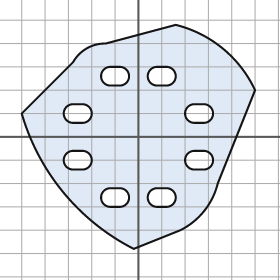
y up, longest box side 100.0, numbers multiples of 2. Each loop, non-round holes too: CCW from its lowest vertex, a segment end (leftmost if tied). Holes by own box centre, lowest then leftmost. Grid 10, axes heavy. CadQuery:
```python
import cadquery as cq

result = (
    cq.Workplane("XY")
    .moveTo(-2.0, -48.0)
    .lineTo(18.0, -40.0)
    .threePointArc((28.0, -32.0), (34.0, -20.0))
    .lineTo(50.0, 20.0)
    .threePointArc((36.0, 38.0), (16.0, 48.0))
    .lineTo(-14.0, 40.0)
    .threePointArc((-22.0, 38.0), (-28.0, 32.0))
    .lineTo(-50.0, 10.0)
    .threePointArc((-32.0, -24.0), (-2.0, -48.0))
    .close()
    .moveTo(-12.0, -30.0)
    .lineTo(-8.0, -30.0)
    .threePointArc((-4.0, -26.0), (-8.0, -22.0))
    .lineTo(-12.0, -22.0)
    .threePointArc((-16.0, -26.0), (-12.0, -30.0))
    .close()
    .moveTo(8.0, -30.0)
    .lineTo(12.0, -30.0)
    .threePointArc((16.0, -26.0), (12.0, -22.0))
    .lineTo(8.0, -22.0)
    .threePointArc((4.0, -26.0), (8.0, -30.0))
    .close()
    .moveTo(-28.0, -14.0)
    .lineTo(-24.0, -14.0)
    .threePointArc((-20.0, -10.0), (-24.0, -6.0))
    .lineTo(-28.0, -6.0)
    .threePointArc((-32.0, -10.0), (-28.0, -14.0))
    .close()
    .moveTo(24.0, -14.0)
    .lineTo(28.0, -14.0)
    .threePointArc((32.0, -10.0), (28.0, -6.0))
    .lineTo(24.0, -6.0)
    .threePointArc((20.0, -10.0), (24.0, -14.0))
    .close()
    .moveTo(-28.0, 6.0)
    .lineTo(-24.0, 6.0)
    .threePointArc((-20.0, 10.0), (-24.0, 14.0))
    .lineTo(-28.0, 14.0)
    .threePointArc((-32.0, 10.0), (-28.0, 6.0))
    .close()
    .moveTo(24.0, 6.0)
    .lineTo(28.0, 6.0)
    .threePointArc((32.0, 10.0), (28.0, 14.0))
    .lineTo(24.0, 14.0)
    .threePointArc((20.0, 10.0), (24.0, 6.0))
    .close()
    .moveTo(-12.0, 22.0)
    .lineTo(-8.0, 22.0)
    .threePointArc((-4.0, 26.0), (-8.0, 30.0))
    .lineTo(-12.0, 30.0)
    .threePointArc((-16.0, 26.0), (-12.0, 22.0))
    .close()
    .moveTo(8.0, 22.0)
    .lineTo(12.0, 22.0)
    .threePointArc((16.0, 26.0), (12.0, 30.0))
    .lineTo(8.0, 30.0)
    .threePointArc((4.0, 26.0), (8.0, 22.0))
    .close()
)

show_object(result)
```